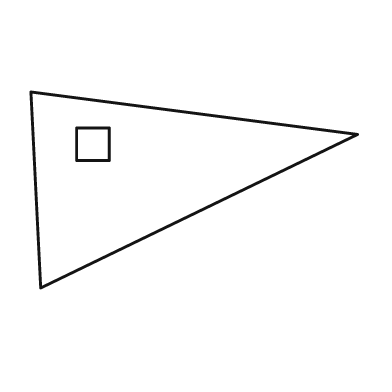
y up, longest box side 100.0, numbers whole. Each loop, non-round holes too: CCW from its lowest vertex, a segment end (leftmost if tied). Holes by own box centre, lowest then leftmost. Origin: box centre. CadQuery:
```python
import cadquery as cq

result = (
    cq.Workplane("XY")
    .moveTo(-47.0, -30.0)
    .lineTo(50.0, 17.0)
    .lineTo(-50.0, 30.0)
    .close()
    .moveTo(-36.0, 9.0)
    .lineTo(-26.0, 9.0)
    .lineTo(-26.0, 19.0)
    .lineTo(-36.0, 19.0)
    .close()
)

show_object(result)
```